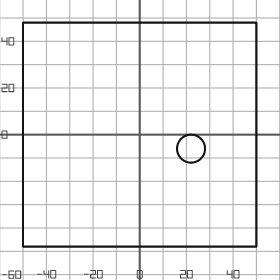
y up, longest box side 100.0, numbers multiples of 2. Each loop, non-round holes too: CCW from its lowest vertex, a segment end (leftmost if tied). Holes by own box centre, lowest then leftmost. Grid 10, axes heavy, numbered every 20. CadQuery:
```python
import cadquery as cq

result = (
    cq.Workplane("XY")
    .moveTo(-50.0, -48.0)
    .lineTo(50.0, -48.0)
    .lineTo(50.0, 48.0)
    .lineTo(-50.0, 48.0)
    .close()
    .moveTo(22.0, -6.0)
    .circle(6.0)
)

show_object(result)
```